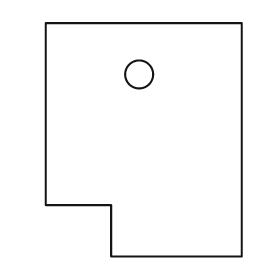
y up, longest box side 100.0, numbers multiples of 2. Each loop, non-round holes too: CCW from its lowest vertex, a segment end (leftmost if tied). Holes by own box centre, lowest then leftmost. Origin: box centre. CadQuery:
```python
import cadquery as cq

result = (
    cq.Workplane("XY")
    .moveTo(-14.0, -50.0)
    .lineTo(42.0, -50.0)
    .lineTo(42.0, 50.0)
    .lineTo(-42.0, 50.0)
    .lineTo(-42.0, -28.0)
    .lineTo(-14.0, -28.0)
    .close()
    .moveTo(-2.0, 28.0)
    .circle(6.0)
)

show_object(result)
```